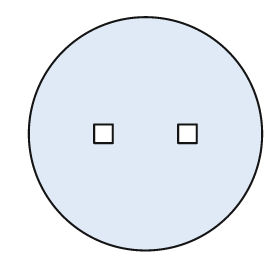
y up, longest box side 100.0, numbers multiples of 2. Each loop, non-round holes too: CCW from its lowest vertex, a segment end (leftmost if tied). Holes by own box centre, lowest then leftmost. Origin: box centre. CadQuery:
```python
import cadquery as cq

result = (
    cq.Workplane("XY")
    .moveTo(0.0, 0.0)
    .circle(50.0)
    .moveTo(-22.0, -4.0)
    .lineTo(-14.0, -4.0)
    .lineTo(-14.0, 4.0)
    .lineTo(-22.0, 4.0)
    .close()
    .moveTo(14.0, -4.0)
    .lineTo(22.0, -4.0)
    .lineTo(22.0, 4.0)
    .lineTo(14.0, 4.0)
    .close()
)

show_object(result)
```